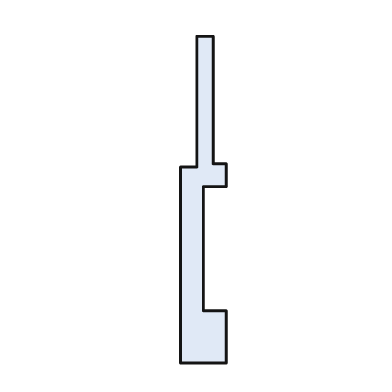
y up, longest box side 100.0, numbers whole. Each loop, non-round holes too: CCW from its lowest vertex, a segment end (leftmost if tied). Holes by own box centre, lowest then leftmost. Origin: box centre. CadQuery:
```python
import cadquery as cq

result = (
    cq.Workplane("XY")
    .moveTo(-7.0, -50.0)
    .lineTo(7.0, -50.0)
    .lineTo(7.0, -34.0)
    .lineTo(0.0, -34.0)
    .lineTo(0.0, 4.0)
    .lineTo(7.0, 4.0)
    .lineTo(7.0, 11.0)
    .lineTo(3.0, 11.0)
    .lineTo(3.0, 50.0)
    .lineTo(-2.0, 50.0)
    .lineTo(-2.0, 10.0)
    .lineTo(-7.0, 10.0)
    .close()
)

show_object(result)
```